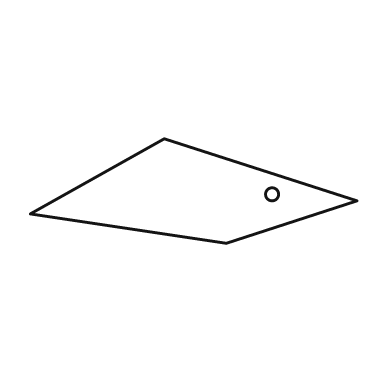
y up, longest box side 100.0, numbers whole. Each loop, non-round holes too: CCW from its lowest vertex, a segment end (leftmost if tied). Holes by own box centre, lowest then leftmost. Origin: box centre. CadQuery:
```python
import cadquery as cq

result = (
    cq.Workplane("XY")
    .moveTo(10.0, -16.0)
    .lineTo(50.0, -3.0)
    .lineTo(-9.0, 16.0)
    .lineTo(-50.0, -7.0)
    .close()
    .moveTo(24.0, -1.0)
    .circle(2.0)
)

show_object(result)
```